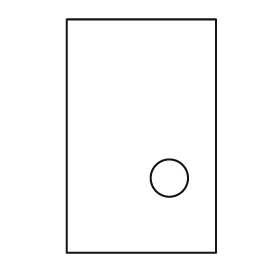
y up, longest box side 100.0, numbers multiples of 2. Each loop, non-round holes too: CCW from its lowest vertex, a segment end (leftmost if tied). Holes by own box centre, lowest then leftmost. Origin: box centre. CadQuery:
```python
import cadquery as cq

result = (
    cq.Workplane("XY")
    .moveTo(-32.0, -50.0)
    .lineTo(32.0, -50.0)
    .lineTo(32.0, 50.0)
    .lineTo(-32.0, 50.0)
    .close()
    .moveTo(12.0, -18.0)
    .circle(8.0)
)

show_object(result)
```